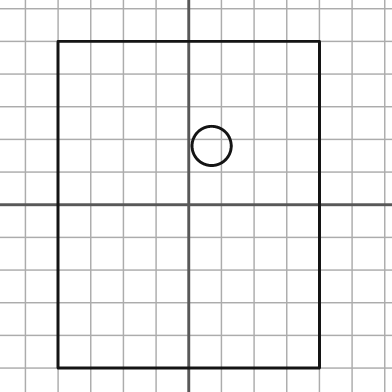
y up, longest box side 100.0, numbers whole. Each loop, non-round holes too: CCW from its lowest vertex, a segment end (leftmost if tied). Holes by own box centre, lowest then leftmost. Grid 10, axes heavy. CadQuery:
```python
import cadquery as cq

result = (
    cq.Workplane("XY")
    .moveTo(-40.0, -50.0)
    .lineTo(40.0, -50.0)
    .lineTo(40.0, 50.0)
    .lineTo(-40.0, 50.0)
    .close()
    .moveTo(7.0, 18.0)
    .circle(6.0)
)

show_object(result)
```